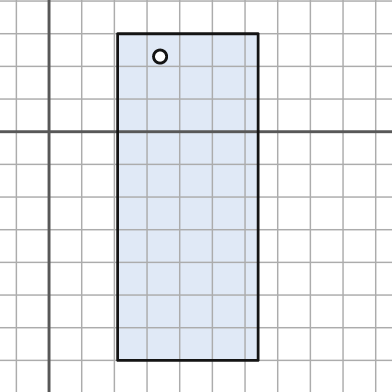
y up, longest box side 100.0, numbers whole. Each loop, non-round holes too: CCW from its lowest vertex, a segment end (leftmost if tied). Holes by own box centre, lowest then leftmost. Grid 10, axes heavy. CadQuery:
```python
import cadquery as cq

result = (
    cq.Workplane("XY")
    .moveTo(21.0, -70.0)
    .lineTo(64.0, -70.0)
    .lineTo(64.0, 30.0)
    .lineTo(21.0, 30.0)
    .close()
    .moveTo(34.0, 23.0)
    .circle(2.0)
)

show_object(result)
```